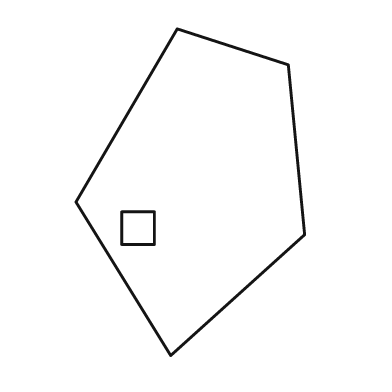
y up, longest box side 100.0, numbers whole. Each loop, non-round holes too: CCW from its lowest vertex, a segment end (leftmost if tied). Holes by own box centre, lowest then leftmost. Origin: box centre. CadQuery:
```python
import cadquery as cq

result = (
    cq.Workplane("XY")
    .moveTo(-6.0, -50.0)
    .lineTo(35.0, -13.0)
    .lineTo(30.0, 39.0)
    .lineTo(-4.0, 50.0)
    .lineTo(-35.0, -3.0)
    .close()
    .moveTo(-21.0, -16.0)
    .lineTo(-11.0, -16.0)
    .lineTo(-11.0, -6.0)
    .lineTo(-21.0, -6.0)
    .close()
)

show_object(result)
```